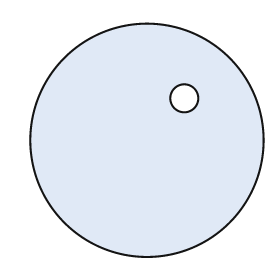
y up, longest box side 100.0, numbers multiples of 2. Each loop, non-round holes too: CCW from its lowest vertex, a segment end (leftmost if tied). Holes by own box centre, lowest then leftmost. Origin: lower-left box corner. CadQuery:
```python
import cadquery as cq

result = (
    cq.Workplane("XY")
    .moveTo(50.0, 50.0)
    .circle(50.0)
    .moveTo(66.0, 68.0)
    .circle(6.0)
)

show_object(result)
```